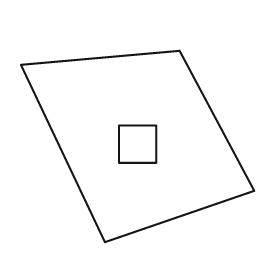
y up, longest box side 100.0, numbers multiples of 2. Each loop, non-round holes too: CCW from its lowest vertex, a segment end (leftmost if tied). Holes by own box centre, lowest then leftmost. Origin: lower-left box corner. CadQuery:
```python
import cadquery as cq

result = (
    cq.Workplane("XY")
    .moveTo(36.0, 0.0)
    .lineTo(100.0, 22.0)
    .lineTo(68.0, 82.0)
    .lineTo(0.0, 76.0)
    .close()
    .moveTo(42.0, 34.0)
    .lineTo(58.0, 34.0)
    .lineTo(58.0, 50.0)
    .lineTo(42.0, 50.0)
    .close()
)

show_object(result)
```